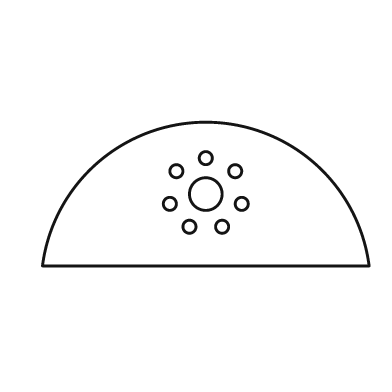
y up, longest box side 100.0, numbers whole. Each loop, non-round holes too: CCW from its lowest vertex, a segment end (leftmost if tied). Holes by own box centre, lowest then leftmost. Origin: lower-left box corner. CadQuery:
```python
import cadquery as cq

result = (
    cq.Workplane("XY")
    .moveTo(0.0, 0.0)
    .lineTo(100.0, 0.0)
    .threePointArc((50.0, 44.0), (0.0, 0.0))
    .close()
    .moveTo(45.0, 12.0)
    .circle(2.0)
    .moveTo(55.0, 12.0)
    .circle(2.0)
    .moveTo(39.0, 19.0)
    .circle(2.0)
    .moveTo(61.0, 19.0)
    .circle(2.0)
    .moveTo(50.0, 22.0)
    .circle(5.0)
    .moveTo(41.0, 29.0)
    .circle(2.0)
    .moveTo(59.0, 29.0)
    .circle(2.0)
    .moveTo(50.0, 33.0)
    .circle(2.0)
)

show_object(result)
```